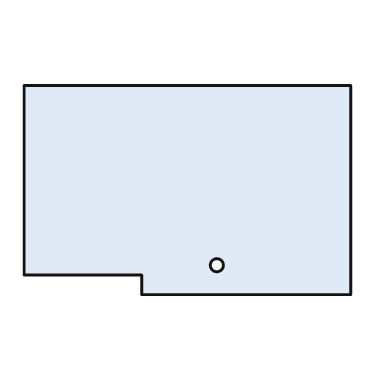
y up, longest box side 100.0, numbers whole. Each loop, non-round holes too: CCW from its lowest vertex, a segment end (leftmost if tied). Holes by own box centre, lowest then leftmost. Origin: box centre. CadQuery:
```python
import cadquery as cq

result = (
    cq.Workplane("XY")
    .moveTo(-14.0, -32.0)
    .lineTo(50.0, -32.0)
    .lineTo(50.0, 32.0)
    .lineTo(-50.0, 32.0)
    .lineTo(-50.0, -26.0)
    .lineTo(-14.0, -26.0)
    .close()
    .moveTo(9.0, -23.0)
    .circle(2.0)
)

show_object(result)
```